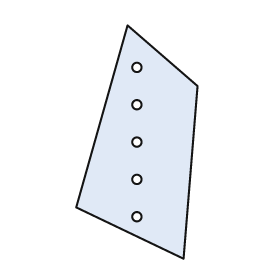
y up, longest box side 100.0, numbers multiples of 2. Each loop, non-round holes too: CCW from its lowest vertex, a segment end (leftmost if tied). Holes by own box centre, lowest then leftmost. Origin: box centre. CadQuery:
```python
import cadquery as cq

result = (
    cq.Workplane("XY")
    .moveTo(20.0, -50.0)
    .lineTo(26.0, 24.0)
    .lineTo(-4.0, 50.0)
    .lineTo(-26.0, -28.0)
    .close()
    .moveTo(0.0, -32.0)
    .circle(2.0)
    .moveTo(0.0, -16.0)
    .circle(2.0)
    .moveTo(0.0, 0.0)
    .circle(2.0)
    .moveTo(0.0, 16.0)
    .circle(2.0)
    .moveTo(0.0, 32.0)
    .circle(2.0)
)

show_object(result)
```